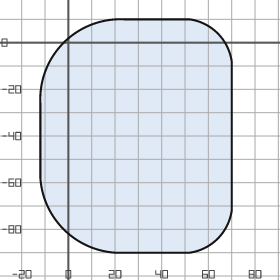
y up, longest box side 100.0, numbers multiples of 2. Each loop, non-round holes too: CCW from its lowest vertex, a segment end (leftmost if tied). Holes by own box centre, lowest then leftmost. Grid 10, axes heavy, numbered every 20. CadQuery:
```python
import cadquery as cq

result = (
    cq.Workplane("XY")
    .moveTo(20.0, -90.0)
    .lineTo(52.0, -90.0)
    .threePointArc((64.0, -84.0), (70.0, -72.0))
    .lineTo(70.0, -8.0)
    .threePointArc((64.0, 4.0), (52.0, 10.0))
    .lineTo(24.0, 10.0)
    .threePointArc((-2.0, 0.0), (-12.0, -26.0))
    .lineTo(-12.0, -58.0)
    .threePointArc((-2.0, -80.0), (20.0, -90.0))
    .close()
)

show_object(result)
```